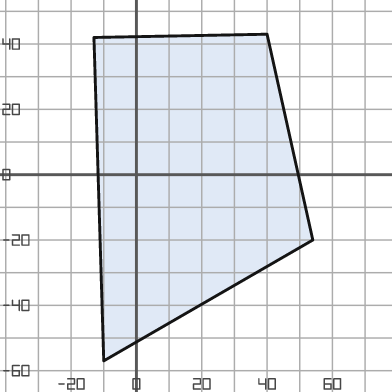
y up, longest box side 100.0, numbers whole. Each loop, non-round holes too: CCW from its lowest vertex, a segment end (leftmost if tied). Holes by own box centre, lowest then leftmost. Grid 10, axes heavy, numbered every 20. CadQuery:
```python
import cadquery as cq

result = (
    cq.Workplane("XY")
    .moveTo(-10.0, -57.0)
    .lineTo(54.0, -20.0)
    .lineTo(40.0, 43.0)
    .lineTo(-13.0, 42.0)
    .close()
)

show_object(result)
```